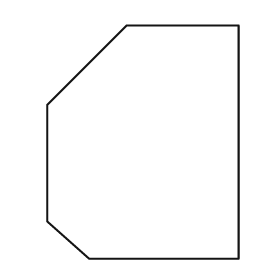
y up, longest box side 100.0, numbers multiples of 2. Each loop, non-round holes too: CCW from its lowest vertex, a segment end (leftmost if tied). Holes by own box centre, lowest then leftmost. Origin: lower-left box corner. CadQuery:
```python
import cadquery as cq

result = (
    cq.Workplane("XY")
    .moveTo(18.0, 0.0)
    .lineTo(82.0, 0.0)
    .lineTo(82.0, 100.0)
    .lineTo(34.0, 100.0)
    .lineTo(0.0, 66.0)
    .lineTo(0.0, 16.0)
    .close()
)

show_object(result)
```